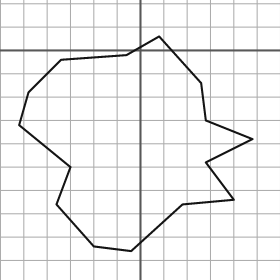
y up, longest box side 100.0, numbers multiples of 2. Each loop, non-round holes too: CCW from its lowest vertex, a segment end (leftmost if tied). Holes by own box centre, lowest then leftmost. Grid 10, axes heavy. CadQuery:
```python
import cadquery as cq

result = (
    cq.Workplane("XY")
    .moveTo(-4.0, -86.0)
    .lineTo(18.0, -66.0)
    .lineTo(40.0, -64.0)
    .lineTo(28.0, -48.0)
    .lineTo(48.0, -38.0)
    .lineTo(28.0, -30.0)
    .lineTo(26.0, -14.0)
    .lineTo(8.0, 6.0)
    .lineTo(-6.0, -2.0)
    .lineTo(-34.0, -4.0)
    .lineTo(-48.0, -18.0)
    .lineTo(-52.0, -32.0)
    .lineTo(-30.0, -50.0)
    .lineTo(-36.0, -66.0)
    .lineTo(-20.0, -84.0)
    .close()
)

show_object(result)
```